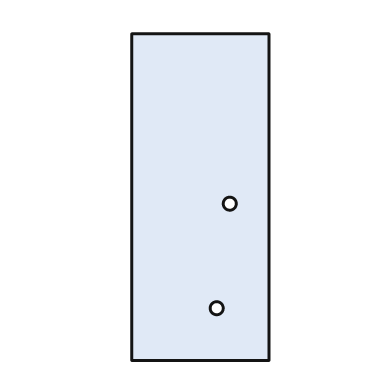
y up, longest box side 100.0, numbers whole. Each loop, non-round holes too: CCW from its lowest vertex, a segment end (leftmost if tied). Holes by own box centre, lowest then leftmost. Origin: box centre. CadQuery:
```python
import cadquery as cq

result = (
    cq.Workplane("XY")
    .moveTo(-21.0, -50.0)
    .lineTo(21.0, -50.0)
    .lineTo(21.0, 50.0)
    .lineTo(-21.0, 50.0)
    .close()
    .moveTo(5.0, -34.0)
    .circle(2.0)
    .moveTo(9.0, -2.0)
    .circle(2.0)
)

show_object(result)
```